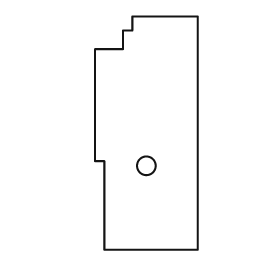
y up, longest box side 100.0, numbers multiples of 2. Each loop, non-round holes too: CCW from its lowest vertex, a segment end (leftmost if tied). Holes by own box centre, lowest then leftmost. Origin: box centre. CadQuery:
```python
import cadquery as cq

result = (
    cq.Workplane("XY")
    .moveTo(-18.0, -50.0)
    .lineTo(22.0, -50.0)
    .lineTo(22.0, 50.0)
    .lineTo(-6.0, 50.0)
    .lineTo(-6.0, 44.0)
    .lineTo(-10.0, 44.0)
    .lineTo(-10.0, 36.0)
    .lineTo(-22.0, 36.0)
    .lineTo(-22.0, -12.0)
    .lineTo(-18.0, -12.0)
    .close()
    .moveTo(0.0, -14.0)
    .circle(4.0)
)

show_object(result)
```